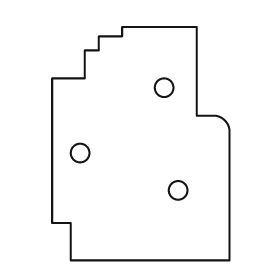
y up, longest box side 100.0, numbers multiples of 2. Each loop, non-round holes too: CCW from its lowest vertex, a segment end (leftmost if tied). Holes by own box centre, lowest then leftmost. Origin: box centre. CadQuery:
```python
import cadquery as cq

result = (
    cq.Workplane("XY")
    .moveTo(-30.0, -50.0)
    .lineTo(38.0, -50.0)
    .lineTo(38.0, 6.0)
    .threePointArc((36.0, 10.0), (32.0, 12.0))
    .lineTo(24.0, 12.0)
    .lineTo(24.0, 50.0)
    .lineTo(-8.0, 50.0)
    .lineTo(-8.0, 46.0)
    .lineTo(-18.0, 46.0)
    .lineTo(-18.0, 40.0)
    .lineTo(-24.0, 40.0)
    .lineTo(-24.0, 28.0)
    .lineTo(-38.0, 28.0)
    .lineTo(-38.0, -34.0)
    .lineTo(-30.0, -34.0)
    .close()
    .moveTo(16.0, -20.0)
    .circle(4.0)
    .moveTo(-26.0, -4.0)
    .circle(4.0)
    .moveTo(10.0, 24.0)
    .circle(4.0)
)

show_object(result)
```